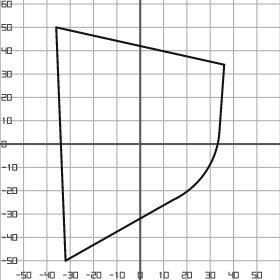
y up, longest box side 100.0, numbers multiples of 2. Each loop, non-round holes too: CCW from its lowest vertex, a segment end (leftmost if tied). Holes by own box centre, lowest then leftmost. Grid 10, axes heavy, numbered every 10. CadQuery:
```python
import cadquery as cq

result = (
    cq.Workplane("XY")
    .moveTo(-32.0, -50.0)
    .lineTo(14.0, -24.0)
    .threePointArc((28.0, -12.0), (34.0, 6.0))
    .lineTo(36.0, 34.0)
    .lineTo(-36.0, 50.0)
    .close()
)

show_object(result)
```